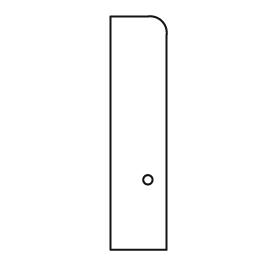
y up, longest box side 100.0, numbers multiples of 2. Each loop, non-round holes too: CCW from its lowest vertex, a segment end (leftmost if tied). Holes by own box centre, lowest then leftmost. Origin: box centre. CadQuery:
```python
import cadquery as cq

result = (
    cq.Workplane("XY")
    .moveTo(-12.0, -50.0)
    .lineTo(12.0, -50.0)
    .lineTo(12.0, 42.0)
    .threePointArc((10.0, 48.0), (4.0, 50.0))
    .lineTo(-12.0, 50.0)
    .close()
    .moveTo(4.0, -20.0)
    .circle(2.0)
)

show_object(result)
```